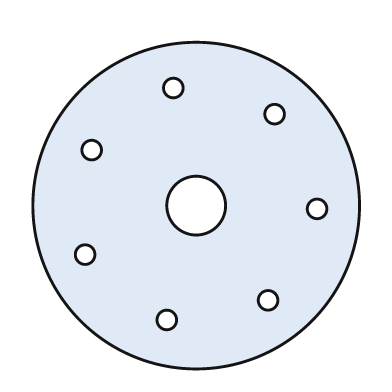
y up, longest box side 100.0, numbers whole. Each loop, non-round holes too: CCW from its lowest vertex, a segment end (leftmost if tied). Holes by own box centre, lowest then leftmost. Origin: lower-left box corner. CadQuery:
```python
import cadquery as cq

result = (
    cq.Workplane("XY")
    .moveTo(50.0, 50.0)
    .circle(50.0)
    .moveTo(41.0, 15.0)
    .circle(3.0)
    .moveTo(72.0, 21.0)
    .circle(3.0)
    .moveTo(16.0, 35.0)
    .circle(3.0)
    .moveTo(87.0, 49.0)
    .circle(3.0)
    .moveTo(50.0, 50.0)
    .circle(9.0)
    .moveTo(18.0, 67.0)
    .circle(3.0)
    .moveTo(74.0, 78.0)
    .circle(3.0)
    .moveTo(43.0, 86.0)
    .circle(3.0)
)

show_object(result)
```